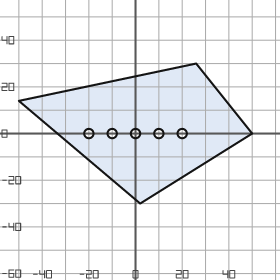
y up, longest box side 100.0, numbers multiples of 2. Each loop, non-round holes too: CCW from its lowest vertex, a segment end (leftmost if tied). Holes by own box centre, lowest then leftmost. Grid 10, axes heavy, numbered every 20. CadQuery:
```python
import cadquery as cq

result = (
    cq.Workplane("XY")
    .moveTo(2.0, -30.0)
    .lineTo(50.0, 0.0)
    .lineTo(26.0, 30.0)
    .lineTo(-50.0, 14.0)
    .close()
    .moveTo(-20.0, 0.0)
    .circle(2.0)
    .moveTo(-10.0, 0.0)
    .circle(2.0)
    .moveTo(0.0, 0.0)
    .circle(2.0)
    .moveTo(10.0, 0.0)
    .circle(2.0)
    .moveTo(20.0, 0.0)
    .circle(2.0)
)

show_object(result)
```